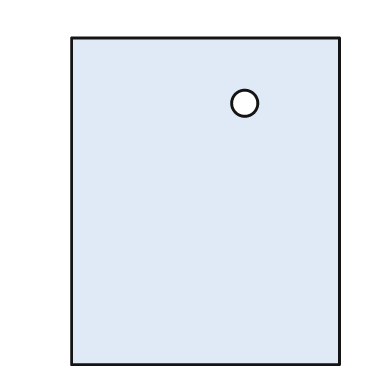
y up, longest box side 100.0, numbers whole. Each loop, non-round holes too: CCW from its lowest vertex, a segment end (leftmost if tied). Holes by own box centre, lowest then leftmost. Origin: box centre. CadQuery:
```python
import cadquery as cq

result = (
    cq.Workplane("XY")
    .moveTo(-41.0, -50.0)
    .lineTo(41.0, -50.0)
    .lineTo(41.0, 50.0)
    .lineTo(-41.0, 50.0)
    .close()
    .moveTo(12.0, 30.0)
    .circle(4.0)
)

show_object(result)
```